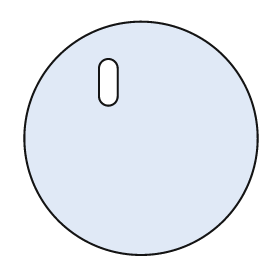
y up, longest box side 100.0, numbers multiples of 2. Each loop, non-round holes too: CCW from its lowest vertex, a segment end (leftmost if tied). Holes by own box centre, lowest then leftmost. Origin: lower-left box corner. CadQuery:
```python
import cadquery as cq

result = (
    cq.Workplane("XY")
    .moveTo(50.0, 50.0)
    .circle(50.0)
    .moveTo(32.0, 68.0)
    .threePointArc((36.0, 64.0), (40.0, 68.0))
    .lineTo(40.0, 80.0)
    .threePointArc((36.0, 84.0), (32.0, 80.0))
    .close()
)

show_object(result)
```